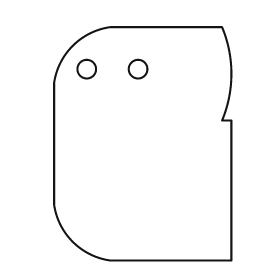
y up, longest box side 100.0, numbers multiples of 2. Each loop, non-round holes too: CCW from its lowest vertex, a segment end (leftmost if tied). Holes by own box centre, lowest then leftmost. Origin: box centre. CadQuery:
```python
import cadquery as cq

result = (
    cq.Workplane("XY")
    .moveTo(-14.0, -50.0)
    .lineTo(38.0, -50.0)
    .lineTo(38.0, 10.0)
    .lineTo(34.0, 10.0)
    .threePointArc((38.0, 30.0), (34.0, 50.0))
    .lineTo(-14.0, 50.0)
    .threePointArc((-30.0, 42.0), (-38.0, 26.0))
    .lineTo(-38.0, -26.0)
    .threePointArc((-30.0, -42.0), (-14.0, -50.0))
    .close()
    .moveTo(-24.0, 32.0)
    .circle(4.0)
    .moveTo(-2.0, 32.0)
    .circle(4.0)
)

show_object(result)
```